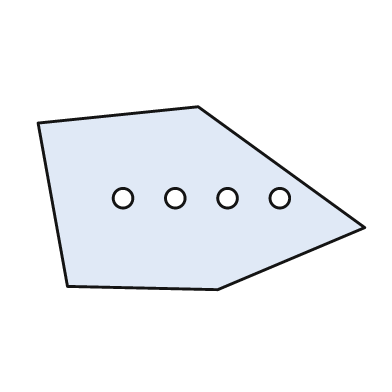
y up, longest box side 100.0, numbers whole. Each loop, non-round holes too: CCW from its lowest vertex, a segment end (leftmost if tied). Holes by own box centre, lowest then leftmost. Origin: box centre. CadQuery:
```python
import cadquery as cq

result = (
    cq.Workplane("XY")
    .moveTo(5.0, -28.0)
    .lineTo(50.0, -9.0)
    .lineTo(-1.0, 28.0)
    .lineTo(-50.0, 23.0)
    .lineTo(-41.0, -27.0)
    .close()
    .moveTo(-24.0, 0.0)
    .circle(3.0)
    .moveTo(-8.0, 0.0)
    .circle(3.0)
    .moveTo(8.0, 0.0)
    .circle(3.0)
    .moveTo(24.0, 0.0)
    .circle(3.0)
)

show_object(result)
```